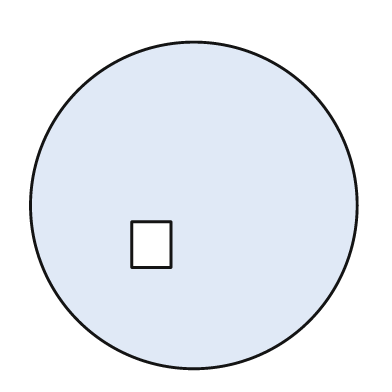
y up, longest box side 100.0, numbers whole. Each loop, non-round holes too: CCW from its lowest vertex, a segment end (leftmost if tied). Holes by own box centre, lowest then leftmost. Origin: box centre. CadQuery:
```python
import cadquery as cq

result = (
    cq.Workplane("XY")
    .moveTo(0.0, 0.0)
    .circle(50.0)
    .moveTo(-19.0, -19.0)
    .lineTo(-7.0, -19.0)
    .lineTo(-7.0, -5.0)
    .lineTo(-19.0, -5.0)
    .close()
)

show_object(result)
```